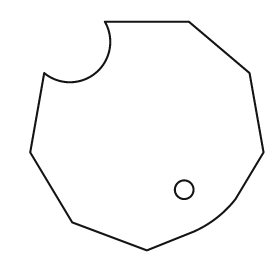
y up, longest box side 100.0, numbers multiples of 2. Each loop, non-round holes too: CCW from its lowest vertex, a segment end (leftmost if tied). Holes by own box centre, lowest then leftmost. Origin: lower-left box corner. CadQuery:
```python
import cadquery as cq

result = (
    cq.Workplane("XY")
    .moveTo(50.0, 0.0)
    .lineTo(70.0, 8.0)
    .threePointArc((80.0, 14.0), (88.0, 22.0))
    .lineTo(100.0, 42.0)
    .lineTo(94.0, 76.0)
    .lineTo(68.0, 98.0)
    .lineTo(32.0, 98.0)
    .threePointArc((28.0, 76.0), (6.0, 76.0))
    .lineTo(0.0, 42.0)
    .lineTo(18.0, 12.0)
    .close()
    .moveTo(66.0, 26.0)
    .circle(4.0)
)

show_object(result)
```